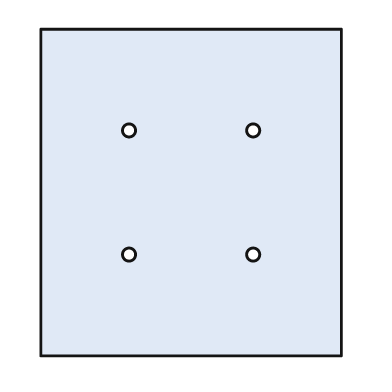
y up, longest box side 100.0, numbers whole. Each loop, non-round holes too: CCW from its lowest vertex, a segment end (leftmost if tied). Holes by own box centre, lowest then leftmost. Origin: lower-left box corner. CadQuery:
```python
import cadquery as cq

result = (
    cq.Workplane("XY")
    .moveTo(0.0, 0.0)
    .lineTo(92.0, 0.0)
    .lineTo(92.0, 100.0)
    .lineTo(0.0, 100.0)
    .close()
    .moveTo(27.0, 31.0)
    .circle(2.0)
    .moveTo(65.0, 31.0)
    .circle(2.0)
    .moveTo(27.0, 69.0)
    .circle(2.0)
    .moveTo(65.0, 69.0)
    .circle(2.0)
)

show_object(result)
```